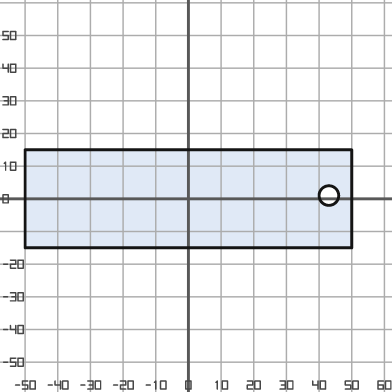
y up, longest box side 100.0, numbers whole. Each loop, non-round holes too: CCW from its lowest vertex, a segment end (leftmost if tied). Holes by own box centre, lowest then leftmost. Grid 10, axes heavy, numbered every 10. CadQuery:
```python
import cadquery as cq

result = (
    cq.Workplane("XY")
    .moveTo(-50.0, -15.0)
    .lineTo(50.0, -15.0)
    .lineTo(50.0, 15.0)
    .lineTo(-50.0, 15.0)
    .close()
    .moveTo(43.0, 1.0)
    .circle(3.0)
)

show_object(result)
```